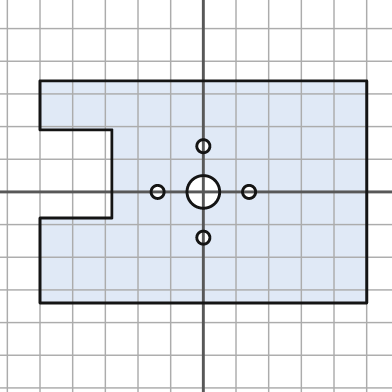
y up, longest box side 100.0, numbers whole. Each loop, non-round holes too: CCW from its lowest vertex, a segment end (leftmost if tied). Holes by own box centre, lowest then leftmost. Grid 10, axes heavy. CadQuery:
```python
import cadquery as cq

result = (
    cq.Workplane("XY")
    .moveTo(-50.0, -34.0)
    .lineTo(50.0, -34.0)
    .lineTo(50.0, 34.0)
    .lineTo(-50.0, 34.0)
    .lineTo(-50.0, 19.0)
    .lineTo(-28.0, 19.0)
    .lineTo(-28.0, -8.0)
    .lineTo(-50.0, -8.0)
    .close()
    .moveTo(0.0, -14.0)
    .circle(2.0)
    .moveTo(-14.0, 0.0)
    .circle(2.0)
    .moveTo(0.0, 0.0)
    .circle(5.0)
    .moveTo(14.0, 0.0)
    .circle(2.0)
    .moveTo(0.0, 14.0)
    .circle(2.0)
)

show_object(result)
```